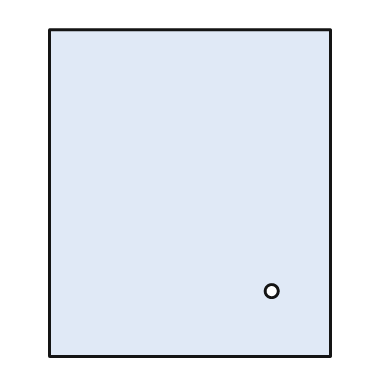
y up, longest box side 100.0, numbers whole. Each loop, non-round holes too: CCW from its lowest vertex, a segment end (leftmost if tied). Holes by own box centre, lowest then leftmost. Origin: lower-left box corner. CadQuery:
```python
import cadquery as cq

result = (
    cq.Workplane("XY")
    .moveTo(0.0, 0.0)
    .lineTo(86.0, 0.0)
    .lineTo(86.0, 100.0)
    .lineTo(0.0, 100.0)
    .close()
    .moveTo(68.0, 20.0)
    .circle(2.0)
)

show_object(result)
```